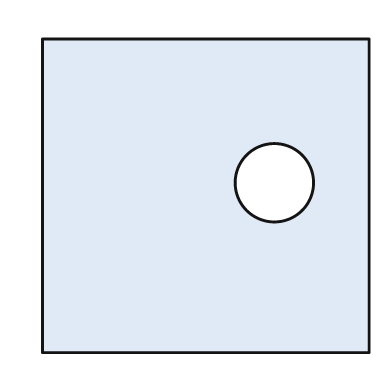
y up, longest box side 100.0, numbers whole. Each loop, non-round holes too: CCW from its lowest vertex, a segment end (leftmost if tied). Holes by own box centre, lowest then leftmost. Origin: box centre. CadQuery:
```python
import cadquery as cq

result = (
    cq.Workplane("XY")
    .moveTo(-50.0, -48.0)
    .lineTo(50.0, -48.0)
    .lineTo(50.0, 48.0)
    .lineTo(-50.0, 48.0)
    .close()
    .moveTo(21.0, 4.0)
    .circle(12.0)
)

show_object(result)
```